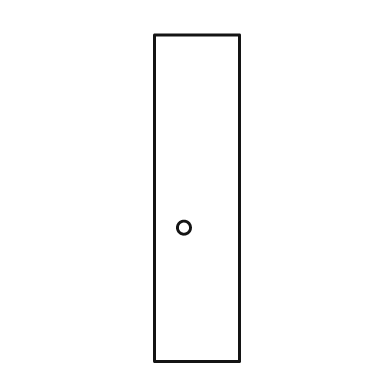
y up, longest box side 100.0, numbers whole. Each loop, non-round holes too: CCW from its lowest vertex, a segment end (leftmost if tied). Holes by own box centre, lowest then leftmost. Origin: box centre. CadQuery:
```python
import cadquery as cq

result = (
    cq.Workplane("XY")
    .moveTo(-13.0, -50.0)
    .lineTo(13.0, -50.0)
    .lineTo(13.0, 50.0)
    .lineTo(-13.0, 50.0)
    .close()
    .moveTo(-4.0, -9.0)
    .circle(2.0)
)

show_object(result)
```